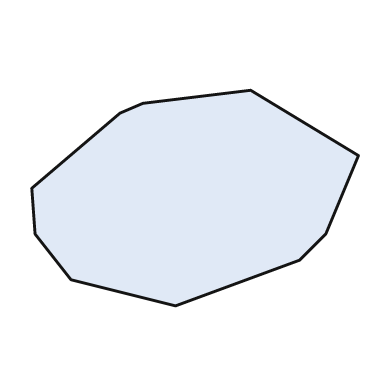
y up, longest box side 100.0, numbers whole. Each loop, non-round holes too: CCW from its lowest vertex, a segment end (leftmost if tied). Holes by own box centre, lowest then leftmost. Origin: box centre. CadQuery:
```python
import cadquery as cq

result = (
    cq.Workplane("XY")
    .moveTo(-6.0, -33.0)
    .lineTo(32.0, -19.0)
    .lineTo(40.0, -11.0)
    .lineTo(50.0, 13.0)
    .lineTo(17.0, 33.0)
    .lineTo(-16.0, 29.0)
    .lineTo(-23.0, 26.0)
    .lineTo(-50.0, 3.0)
    .lineTo(-49.0, -11.0)
    .lineTo(-38.0, -25.0)
    .close()
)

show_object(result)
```